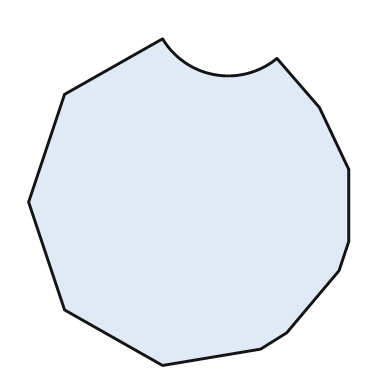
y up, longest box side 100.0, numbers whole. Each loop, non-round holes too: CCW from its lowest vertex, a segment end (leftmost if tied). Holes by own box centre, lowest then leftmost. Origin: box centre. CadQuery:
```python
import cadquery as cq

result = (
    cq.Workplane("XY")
    .moveTo(-8.0, -50.0)
    .lineTo(22.0, -45.0)
    .lineTo(30.0, -40.0)
    .lineTo(46.0, -21.0)
    .lineTo(49.0, -12.0)
    .lineTo(49.0, 10.0)
    .lineTo(40.0, 29.0)
    .lineTo(27.0, 44.0)
    .threePointArc((8.0, 39.0), (-8.0, 50.0))
    .lineTo(-38.0, 33.0)
    .lineTo(-49.0, 0.0)
    .lineTo(-38.0, -33.0)
    .close()
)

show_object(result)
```